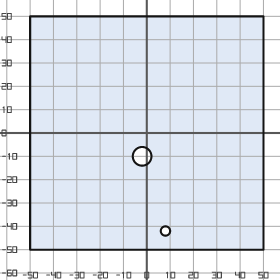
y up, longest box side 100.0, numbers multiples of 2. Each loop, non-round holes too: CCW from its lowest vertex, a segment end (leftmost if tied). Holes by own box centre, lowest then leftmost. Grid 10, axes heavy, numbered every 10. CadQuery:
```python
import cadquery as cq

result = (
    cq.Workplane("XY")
    .moveTo(-50.0, -50.0)
    .lineTo(50.0, -50.0)
    .lineTo(50.0, 50.0)
    .lineTo(-50.0, 50.0)
    .close()
    .moveTo(8.0, -42.0)
    .circle(2.0)
    .moveTo(-2.0, -10.0)
    .circle(4.0)
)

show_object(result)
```